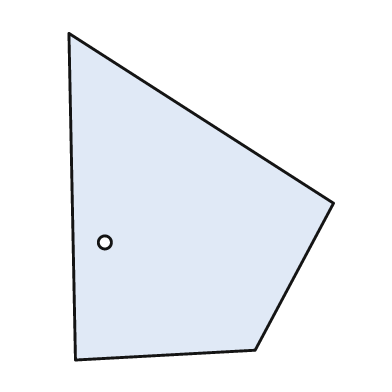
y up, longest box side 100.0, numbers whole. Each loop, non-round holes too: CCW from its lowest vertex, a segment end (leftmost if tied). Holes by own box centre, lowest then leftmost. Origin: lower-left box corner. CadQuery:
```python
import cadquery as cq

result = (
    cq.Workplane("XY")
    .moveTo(2.0, 0.0)
    .lineTo(57.0, 3.0)
    .lineTo(81.0, 48.0)
    .lineTo(0.0, 100.0)
    .close()
    .moveTo(11.0, 36.0)
    .circle(2.0)
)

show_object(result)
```